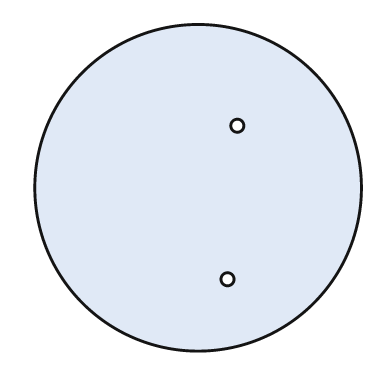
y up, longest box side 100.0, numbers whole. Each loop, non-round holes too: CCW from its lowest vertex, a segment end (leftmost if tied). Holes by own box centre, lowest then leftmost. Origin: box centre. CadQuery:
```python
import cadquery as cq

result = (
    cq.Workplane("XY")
    .moveTo(0.0, 0.0)
    .circle(50.0)
    .moveTo(9.0, -28.0)
    .circle(2.0)
    .moveTo(12.0, 19.0)
    .circle(2.0)
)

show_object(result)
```